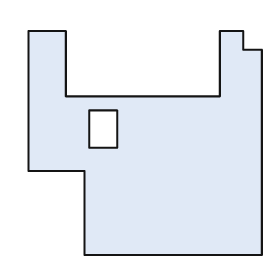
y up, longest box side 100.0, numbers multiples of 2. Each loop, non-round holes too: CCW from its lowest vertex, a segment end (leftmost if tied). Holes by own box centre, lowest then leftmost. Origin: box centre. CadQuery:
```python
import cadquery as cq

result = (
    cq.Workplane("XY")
    .moveTo(-26.0, -48.0)
    .lineTo(50.0, -48.0)
    .lineTo(50.0, 40.0)
    .lineTo(42.0, 40.0)
    .lineTo(42.0, 48.0)
    .lineTo(32.0, 48.0)
    .lineTo(32.0, 20.0)
    .lineTo(-34.0, 20.0)
    .lineTo(-34.0, 48.0)
    .lineTo(-50.0, 48.0)
    .lineTo(-50.0, -12.0)
    .lineTo(-26.0, -12.0)
    .close()
    .moveTo(-24.0, -2.0)
    .lineTo(-12.0, -2.0)
    .lineTo(-12.0, 14.0)
    .lineTo(-24.0, 14.0)
    .close()
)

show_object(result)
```